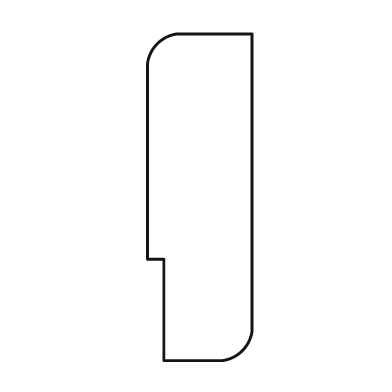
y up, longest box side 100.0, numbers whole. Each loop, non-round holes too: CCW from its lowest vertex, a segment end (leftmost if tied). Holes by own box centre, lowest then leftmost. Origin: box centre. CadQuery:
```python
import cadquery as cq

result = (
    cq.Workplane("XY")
    .moveTo(-11.0, -50.0)
    .lineTo(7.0, -50.0)
    .threePointArc((13.0, -47.0), (16.0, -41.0))
    .lineTo(16.0, 50.0)
    .lineTo(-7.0, 50.0)
    .threePointArc((-13.0, 47.0), (-16.0, 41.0))
    .lineTo(-16.0, -19.0)
    .lineTo(-11.0, -19.0)
    .close()
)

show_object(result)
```